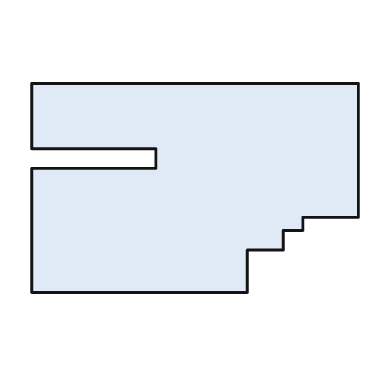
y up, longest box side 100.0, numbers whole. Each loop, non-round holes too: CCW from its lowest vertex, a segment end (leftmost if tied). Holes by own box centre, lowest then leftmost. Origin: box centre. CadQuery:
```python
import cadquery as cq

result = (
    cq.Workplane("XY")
    .moveTo(-50.0, -32.0)
    .lineTo(16.0, -32.0)
    .lineTo(16.0, -19.0)
    .lineTo(27.0, -19.0)
    .lineTo(27.0, -13.0)
    .lineTo(33.0, -13.0)
    .lineTo(33.0, -9.0)
    .lineTo(50.0, -9.0)
    .lineTo(50.0, 32.0)
    .lineTo(-50.0, 32.0)
    .lineTo(-50.0, 12.0)
    .lineTo(-12.0, 12.0)
    .lineTo(-12.0, 6.0)
    .lineTo(-50.0, 6.0)
    .close()
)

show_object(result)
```